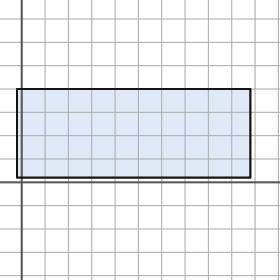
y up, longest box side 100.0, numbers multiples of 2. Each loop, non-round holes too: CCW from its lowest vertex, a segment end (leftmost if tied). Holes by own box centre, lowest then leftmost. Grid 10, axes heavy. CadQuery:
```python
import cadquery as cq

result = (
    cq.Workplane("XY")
    .moveTo(-2.0, 2.0)
    .lineTo(98.0, 2.0)
    .lineTo(98.0, 40.0)
    .lineTo(-2.0, 40.0)
    .close()
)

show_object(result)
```